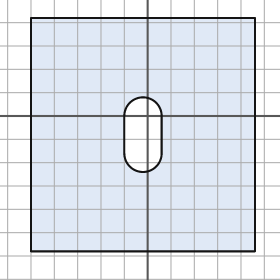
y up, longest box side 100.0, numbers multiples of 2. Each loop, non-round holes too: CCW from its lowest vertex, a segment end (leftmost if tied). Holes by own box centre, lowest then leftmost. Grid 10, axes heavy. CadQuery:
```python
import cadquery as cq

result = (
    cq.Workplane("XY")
    .moveTo(-50.0, -58.0)
    .lineTo(46.0, -58.0)
    .lineTo(46.0, 42.0)
    .lineTo(-50.0, 42.0)
    .close()
    .moveTo(-10.0, -16.0)
    .threePointArc((-2.0, -24.0), (6.0, -16.0))
    .lineTo(6.0, 0.0)
    .threePointArc((-2.0, 8.0), (-10.0, 0.0))
    .close()
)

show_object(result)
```